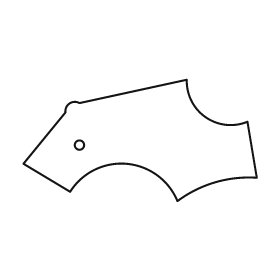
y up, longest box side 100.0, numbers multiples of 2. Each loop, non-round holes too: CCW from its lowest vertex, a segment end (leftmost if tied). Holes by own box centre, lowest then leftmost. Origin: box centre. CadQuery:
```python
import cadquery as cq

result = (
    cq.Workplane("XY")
    .moveTo(16.0, -26.0)
    .threePointArc((32.0, -18.0), (50.0, -16.0))
    .lineTo(46.0, 8.0)
    .threePointArc((28.0, 10.0), (20.0, 26.0))
    .lineTo(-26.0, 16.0)
    .threePointArc((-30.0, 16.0), (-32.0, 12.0))
    .lineTo(-50.0, -10.0)
    .lineTo(-30.0, -22.0)
    .threePointArc((-6.0, -10.0), (16.0, -26.0))
    .close()
    .moveTo(-26.0, -2.0)
    .circle(2.0)
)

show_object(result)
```